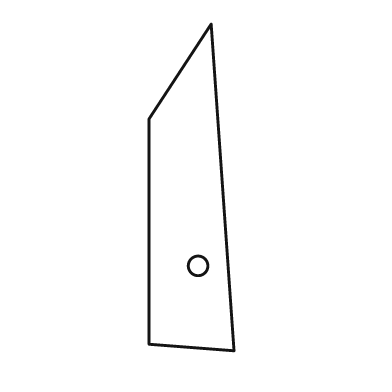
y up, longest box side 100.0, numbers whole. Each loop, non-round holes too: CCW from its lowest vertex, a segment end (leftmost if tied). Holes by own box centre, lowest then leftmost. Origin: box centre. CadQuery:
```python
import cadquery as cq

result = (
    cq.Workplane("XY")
    .moveTo(13.0, -50.0)
    .lineTo(6.0, 50.0)
    .lineTo(-13.0, 21.0)
    .lineTo(-13.0, -48.0)
    .close()
    .moveTo(2.0, -24.0)
    .circle(3.0)
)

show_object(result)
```